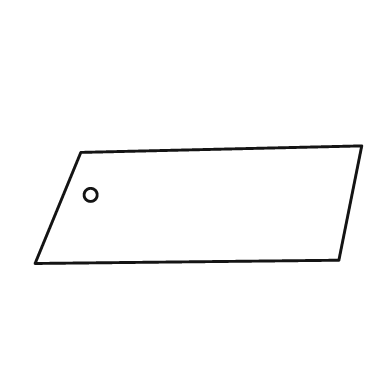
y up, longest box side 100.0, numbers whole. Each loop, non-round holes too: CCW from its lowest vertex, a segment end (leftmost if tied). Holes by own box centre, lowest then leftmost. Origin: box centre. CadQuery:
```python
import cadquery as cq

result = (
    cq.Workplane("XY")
    .moveTo(-50.0, -18.0)
    .lineTo(43.0, -17.0)
    .lineTo(50.0, 18.0)
    .lineTo(-36.0, 16.0)
    .close()
    .moveTo(-33.0, 3.0)
    .circle(2.0)
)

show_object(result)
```